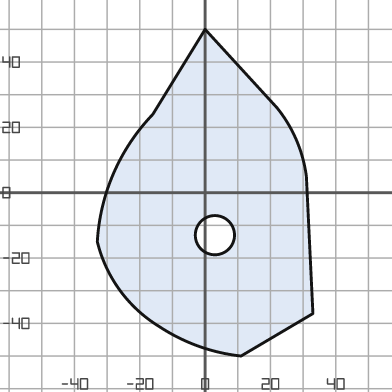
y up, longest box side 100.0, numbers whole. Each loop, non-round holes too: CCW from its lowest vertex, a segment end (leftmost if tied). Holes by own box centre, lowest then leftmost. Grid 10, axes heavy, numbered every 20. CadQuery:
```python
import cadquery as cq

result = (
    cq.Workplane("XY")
    .moveTo(11.0, -50.0)
    .lineTo(33.0, -37.0)
    .lineTo(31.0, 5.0)
    .threePointArc((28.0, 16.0), (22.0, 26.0))
    .lineTo(0.0, 50.0)
    .lineTo(-16.0, 24.0)
    .threePointArc((-28.0, 6.0), (-33.0, -15.0))
    .threePointArc((-26.0, -30.0), (-14.0, -41.0))
    .threePointArc((-2.0, -47.0), (11.0, -50.0))
    .close()
    .moveTo(3.0, -13.0)
    .circle(6.0)
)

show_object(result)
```